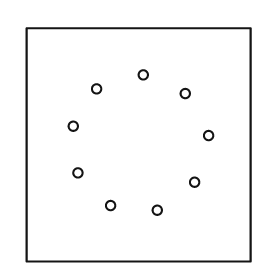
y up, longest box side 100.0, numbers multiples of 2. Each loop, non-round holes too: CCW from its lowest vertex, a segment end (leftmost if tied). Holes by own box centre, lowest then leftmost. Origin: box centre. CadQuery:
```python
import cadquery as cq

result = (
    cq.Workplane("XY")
    .moveTo(-48.0, -50.0)
    .lineTo(48.0, -50.0)
    .lineTo(48.0, 50.0)
    .lineTo(-48.0, 50.0)
    .close()
    .moveTo(8.0, -28.0)
    .circle(2.0)
    .moveTo(-12.0, -26.0)
    .circle(2.0)
    .moveTo(24.0, -16.0)
    .circle(2.0)
    .moveTo(-26.0, -12.0)
    .circle(2.0)
    .moveTo(30.0, 4.0)
    .circle(2.0)
    .moveTo(-28.0, 8.0)
    .circle(2.0)
    .moveTo(20.0, 22.0)
    .circle(2.0)
    .moveTo(-18.0, 24.0)
    .circle(2.0)
    .moveTo(2.0, 30.0)
    .circle(2.0)
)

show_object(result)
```